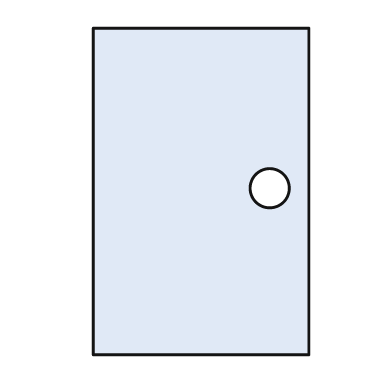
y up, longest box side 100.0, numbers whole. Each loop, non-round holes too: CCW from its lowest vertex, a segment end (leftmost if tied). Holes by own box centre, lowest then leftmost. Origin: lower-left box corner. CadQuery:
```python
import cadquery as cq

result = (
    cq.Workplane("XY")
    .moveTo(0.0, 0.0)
    .lineTo(66.0, 0.0)
    .lineTo(66.0, 100.0)
    .lineTo(0.0, 100.0)
    .close()
    .moveTo(54.0, 51.0)
    .circle(6.0)
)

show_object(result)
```